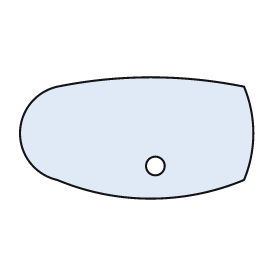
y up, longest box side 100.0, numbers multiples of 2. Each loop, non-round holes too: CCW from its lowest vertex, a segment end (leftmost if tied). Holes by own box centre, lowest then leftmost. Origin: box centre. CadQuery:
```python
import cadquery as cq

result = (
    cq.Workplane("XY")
    .moveTo(-34.0, -18.0)
    .threePointArc((6.0, -26.0), (46.0, -18.0))
    .threePointArc((50.0, 2.0), (46.0, 22.0))
    .threePointArc((6.0, 26.0), (-34.0, 22.0))
    .threePointArc((-50.0, 2.0), (-34.0, -18.0))
    .close()
    .moveTo(8.0, -12.0)
    .circle(4.0)
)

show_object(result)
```